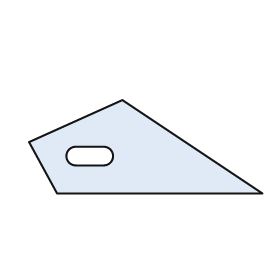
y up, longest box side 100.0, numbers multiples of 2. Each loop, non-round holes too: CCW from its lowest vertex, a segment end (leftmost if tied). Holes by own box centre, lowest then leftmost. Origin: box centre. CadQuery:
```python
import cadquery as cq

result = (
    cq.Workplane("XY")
    .moveTo(-38.0, -20.0)
    .lineTo(50.0, -20.0)
    .lineTo(-10.0, 20.0)
    .lineTo(-50.0, 2.0)
    .close()
    .moveTo(-30.0, -8.0)
    .lineTo(-18.0, -8.0)
    .threePointArc((-14.0, -4.0), (-18.0, 0.0))
    .lineTo(-30.0, 0.0)
    .threePointArc((-34.0, -4.0), (-30.0, -8.0))
    .close()
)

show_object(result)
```